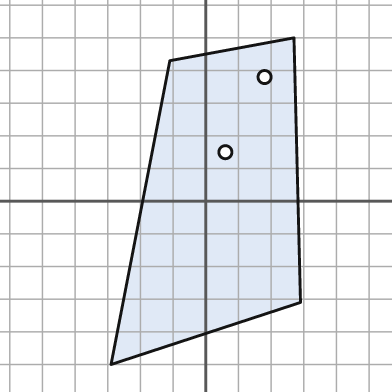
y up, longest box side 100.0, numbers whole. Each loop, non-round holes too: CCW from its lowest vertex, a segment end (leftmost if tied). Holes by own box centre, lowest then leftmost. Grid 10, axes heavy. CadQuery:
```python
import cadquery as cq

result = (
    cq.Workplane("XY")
    .moveTo(-29.0, -50.0)
    .lineTo(29.0, -31.0)
    .lineTo(27.0, 50.0)
    .lineTo(-11.0, 43.0)
    .close()
    .moveTo(6.0, 15.0)
    .circle(2.0)
    .moveTo(18.0, 38.0)
    .circle(2.0)
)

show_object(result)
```